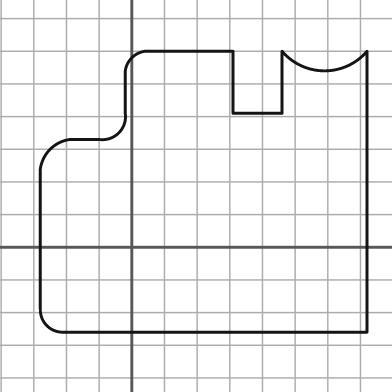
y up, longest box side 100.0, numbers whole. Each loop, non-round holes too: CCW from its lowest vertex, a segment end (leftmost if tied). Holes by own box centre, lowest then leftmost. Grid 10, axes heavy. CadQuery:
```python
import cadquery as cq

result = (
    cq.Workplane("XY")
    .moveTo(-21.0, -26.0)
    .lineTo(72.0, -26.0)
    .lineTo(72.0, 60.0)
    .threePointArc((59.0, 54.0), (46.0, 60.0))
    .lineTo(46.0, 41.0)
    .lineTo(31.0, 41.0)
    .lineTo(31.0, 60.0)
    .lineTo(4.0, 60.0)
    .threePointArc((0.0, 58.0), (-2.0, 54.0))
    .lineTo(-2.0, 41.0)
    .threePointArc((-4.0, 35.0), (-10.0, 33.0))
    .lineTo(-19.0, 33.0)
    .threePointArc((-25.0, 30.0), (-28.0, 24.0))
    .lineTo(-28.0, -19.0)
    .threePointArc((-26.0, -24.0), (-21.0, -26.0))
    .close()
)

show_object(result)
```